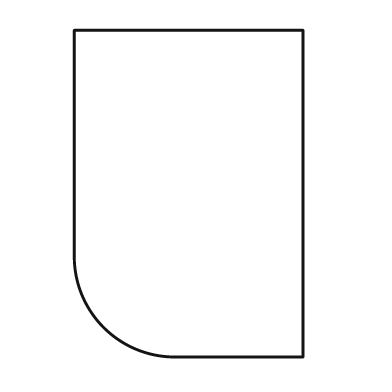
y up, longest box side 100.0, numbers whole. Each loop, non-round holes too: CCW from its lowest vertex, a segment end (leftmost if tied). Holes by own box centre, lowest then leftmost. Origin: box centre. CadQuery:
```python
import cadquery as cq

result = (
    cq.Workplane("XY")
    .moveTo(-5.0, -50.0)
    .lineTo(35.0, -50.0)
    .lineTo(35.0, 50.0)
    .lineTo(-35.0, 50.0)
    .lineTo(-35.0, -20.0)
    .threePointArc((-26.0, -41.0), (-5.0, -50.0))
    .close()
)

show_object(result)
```